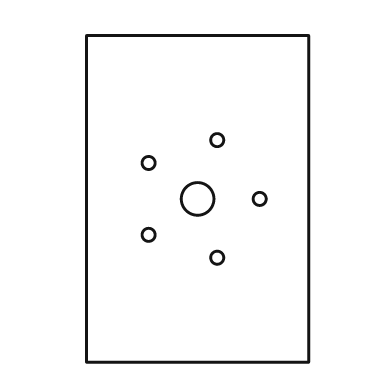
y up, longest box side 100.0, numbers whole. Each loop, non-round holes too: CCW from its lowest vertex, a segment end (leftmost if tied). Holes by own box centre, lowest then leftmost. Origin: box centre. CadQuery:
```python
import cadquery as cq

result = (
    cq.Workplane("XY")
    .moveTo(-34.0, -50.0)
    .lineTo(34.0, -50.0)
    .lineTo(34.0, 50.0)
    .lineTo(-34.0, 50.0)
    .close()
    .moveTo(6.0, -18.0)
    .circle(2.0)
    .moveTo(-15.0, -11.0)
    .circle(2.0)
    .moveTo(0.0, 0.0)
    .circle(5.0)
    .moveTo(19.0, 0.0)
    .circle(2.0)
    .moveTo(-15.0, 11.0)
    .circle(2.0)
    .moveTo(6.0, 18.0)
    .circle(2.0)
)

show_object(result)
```